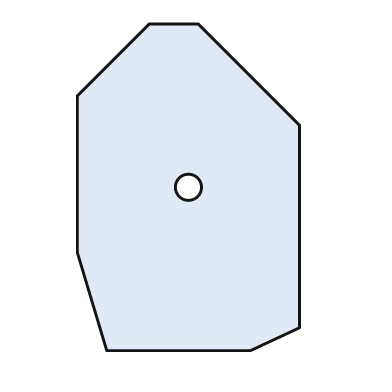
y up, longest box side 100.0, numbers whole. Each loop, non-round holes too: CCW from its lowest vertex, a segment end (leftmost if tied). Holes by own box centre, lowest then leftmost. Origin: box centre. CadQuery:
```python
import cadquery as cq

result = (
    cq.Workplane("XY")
    .moveTo(-25.0, -50.0)
    .lineTo(19.0, -50.0)
    .lineTo(34.0, -43.0)
    .lineTo(34.0, 19.0)
    .lineTo(3.0, 50.0)
    .lineTo(-12.0, 50.0)
    .lineTo(-34.0, 28.0)
    .lineTo(-34.0, -20.0)
    .close()
    .moveTo(0.0, 0.0)
    .circle(4.0)
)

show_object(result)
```